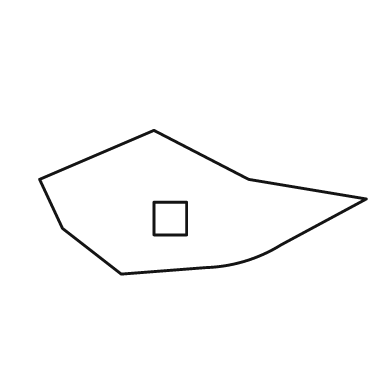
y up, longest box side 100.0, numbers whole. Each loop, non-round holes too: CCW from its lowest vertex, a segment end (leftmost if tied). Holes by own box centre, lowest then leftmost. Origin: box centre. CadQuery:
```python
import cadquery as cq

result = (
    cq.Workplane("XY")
    .moveTo(-25.0, -22.0)
    .lineTo(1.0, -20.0)
    .threePointArc((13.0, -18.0), (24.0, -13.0))
    .lineTo(50.0, 1.0)
    .lineTo(14.0, 7.0)
    .lineTo(-15.0, 22.0)
    .lineTo(-50.0, 7.0)
    .lineTo(-43.0, -8.0)
    .close()
    .moveTo(-15.0, -10.0)
    .lineTo(-5.0, -10.0)
    .lineTo(-5.0, 0.0)
    .lineTo(-15.0, 0.0)
    .close()
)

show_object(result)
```